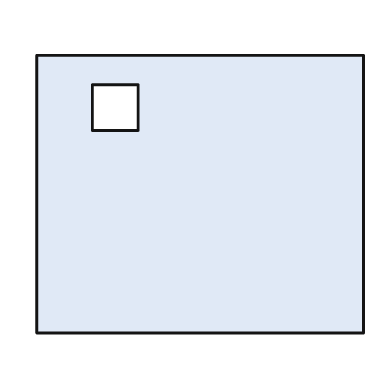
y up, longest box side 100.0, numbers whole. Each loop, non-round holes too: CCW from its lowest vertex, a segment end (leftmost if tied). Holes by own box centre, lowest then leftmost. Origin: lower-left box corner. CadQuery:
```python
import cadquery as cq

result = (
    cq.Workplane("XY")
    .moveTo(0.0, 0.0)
    .lineTo(100.0, 0.0)
    .lineTo(100.0, 85.0)
    .lineTo(0.0, 85.0)
    .close()
    .moveTo(17.0, 62.0)
    .lineTo(31.0, 62.0)
    .lineTo(31.0, 76.0)
    .lineTo(17.0, 76.0)
    .close()
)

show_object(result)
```